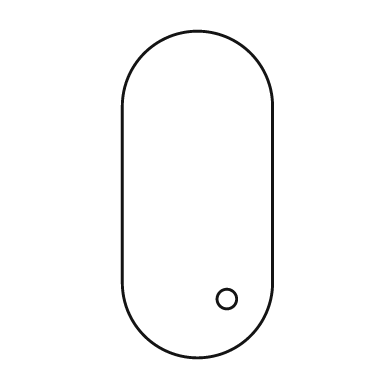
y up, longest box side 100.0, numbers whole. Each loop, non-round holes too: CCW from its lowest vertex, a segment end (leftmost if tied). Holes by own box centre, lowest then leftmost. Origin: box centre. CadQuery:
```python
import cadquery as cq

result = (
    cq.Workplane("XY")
    .moveTo(-23.0, -27.0)
    .threePointArc((0.0, -50.0), (23.0, -27.0))
    .lineTo(23.0, 27.0)
    .threePointArc((0.0, 50.0), (-23.0, 27.0))
    .close()
    .moveTo(9.0, -32.0)
    .circle(3.0)
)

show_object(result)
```